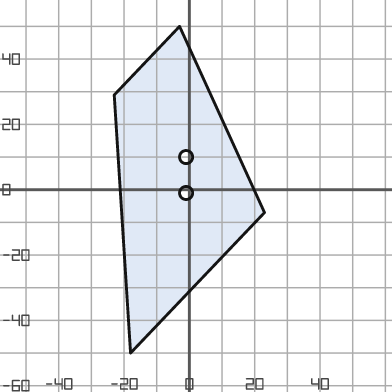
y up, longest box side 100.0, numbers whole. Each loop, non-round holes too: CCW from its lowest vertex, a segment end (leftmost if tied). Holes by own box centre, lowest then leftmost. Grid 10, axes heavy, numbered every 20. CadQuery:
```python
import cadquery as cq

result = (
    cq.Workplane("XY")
    .moveTo(-18.0, -50.0)
    .lineTo(23.0, -7.0)
    .lineTo(-3.0, 50.0)
    .lineTo(-23.0, 29.0)
    .close()
    .moveTo(-1.0, -1.0)
    .circle(2.0)
    .moveTo(-1.0, 10.0)
    .circle(2.0)
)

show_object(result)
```